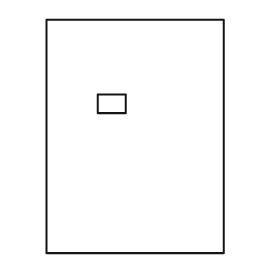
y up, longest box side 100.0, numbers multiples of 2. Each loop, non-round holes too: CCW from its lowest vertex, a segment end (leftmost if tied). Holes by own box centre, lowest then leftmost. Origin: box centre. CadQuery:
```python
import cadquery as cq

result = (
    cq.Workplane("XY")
    .moveTo(-38.0, -50.0)
    .lineTo(38.0, -50.0)
    .lineTo(38.0, 50.0)
    .lineTo(-38.0, 50.0)
    .close()
    .moveTo(-16.0, 10.0)
    .lineTo(-4.0, 10.0)
    .lineTo(-4.0, 18.0)
    .lineTo(-16.0, 18.0)
    .close()
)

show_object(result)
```